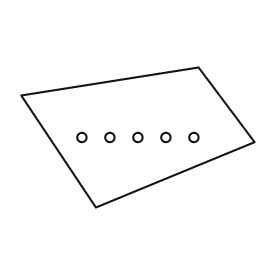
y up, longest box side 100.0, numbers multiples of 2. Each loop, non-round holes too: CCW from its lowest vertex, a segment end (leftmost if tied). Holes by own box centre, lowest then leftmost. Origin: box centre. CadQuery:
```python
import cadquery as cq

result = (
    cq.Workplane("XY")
    .moveTo(-18.0, -30.0)
    .lineTo(50.0, -2.0)
    .lineTo(26.0, 30.0)
    .lineTo(-50.0, 18.0)
    .close()
    .moveTo(-24.0, 0.0)
    .circle(2.0)
    .moveTo(-12.0, 0.0)
    .circle(2.0)
    .moveTo(0.0, 0.0)
    .circle(2.0)
    .moveTo(12.0, 0.0)
    .circle(2.0)
    .moveTo(24.0, 0.0)
    .circle(2.0)
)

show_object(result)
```